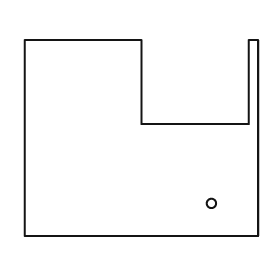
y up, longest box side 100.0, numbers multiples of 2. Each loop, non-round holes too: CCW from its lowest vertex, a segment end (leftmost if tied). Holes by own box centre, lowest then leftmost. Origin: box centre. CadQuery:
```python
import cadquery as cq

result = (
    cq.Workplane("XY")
    .moveTo(-50.0, -42.0)
    .lineTo(50.0, -42.0)
    .lineTo(50.0, 42.0)
    .lineTo(46.0, 42.0)
    .lineTo(46.0, 6.0)
    .lineTo(0.0, 6.0)
    .lineTo(0.0, 42.0)
    .lineTo(-50.0, 42.0)
    .close()
    .moveTo(30.0, -28.0)
    .circle(2.0)
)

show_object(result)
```